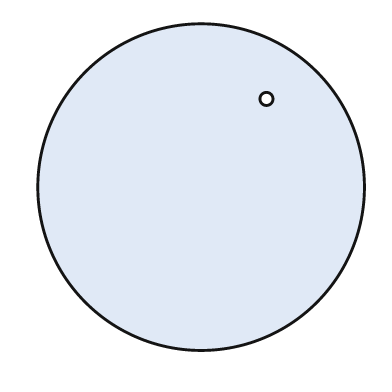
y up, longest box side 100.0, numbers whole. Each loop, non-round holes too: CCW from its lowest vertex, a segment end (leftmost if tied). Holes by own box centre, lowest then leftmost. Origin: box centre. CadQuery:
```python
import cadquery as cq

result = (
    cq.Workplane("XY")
    .moveTo(0.0, 0.0)
    .circle(50.0)
    .moveTo(20.0, 27.0)
    .circle(2.0)
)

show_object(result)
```